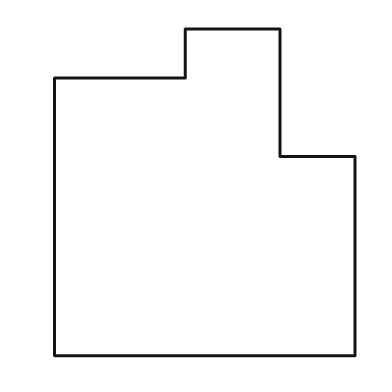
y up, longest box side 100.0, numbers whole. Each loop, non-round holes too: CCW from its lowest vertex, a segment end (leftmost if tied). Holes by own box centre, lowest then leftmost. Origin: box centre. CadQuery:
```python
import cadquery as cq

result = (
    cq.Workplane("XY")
    .moveTo(-46.0, -50.0)
    .lineTo(46.0, -50.0)
    .lineTo(46.0, 11.0)
    .lineTo(23.0, 11.0)
    .lineTo(23.0, 50.0)
    .lineTo(-6.0, 50.0)
    .lineTo(-6.0, 35.0)
    .lineTo(-46.0, 35.0)
    .close()
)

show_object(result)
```